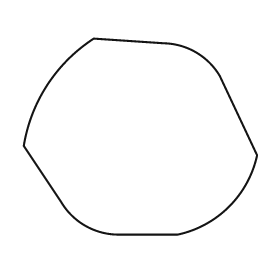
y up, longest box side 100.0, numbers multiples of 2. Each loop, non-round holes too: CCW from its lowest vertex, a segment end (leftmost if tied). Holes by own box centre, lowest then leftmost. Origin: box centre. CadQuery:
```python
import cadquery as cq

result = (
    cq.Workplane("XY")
    .moveTo(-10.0, -42.0)
    .lineTo(16.0, -42.0)
    .threePointArc((38.0, -30.0), (50.0, -8.0))
    .lineTo(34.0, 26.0)
    .threePointArc((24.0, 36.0), (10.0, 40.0))
    .lineTo(-20.0, 42.0)
    .threePointArc((-40.0, 22.0), (-50.0, -4.0))
    .lineTo(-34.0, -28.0)
    .threePointArc((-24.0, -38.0), (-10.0, -42.0))
    .close()
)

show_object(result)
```